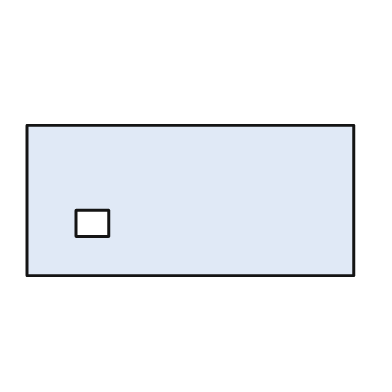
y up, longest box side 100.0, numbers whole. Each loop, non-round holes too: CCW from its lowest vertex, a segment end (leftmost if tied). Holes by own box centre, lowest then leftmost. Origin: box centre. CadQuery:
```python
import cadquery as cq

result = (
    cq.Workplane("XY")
    .moveTo(-50.0, -23.0)
    .lineTo(50.0, -23.0)
    .lineTo(50.0, 23.0)
    .lineTo(-50.0, 23.0)
    .close()
    .moveTo(-35.0, -11.0)
    .lineTo(-25.0, -11.0)
    .lineTo(-25.0, -3.0)
    .lineTo(-35.0, -3.0)
    .close()
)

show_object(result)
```